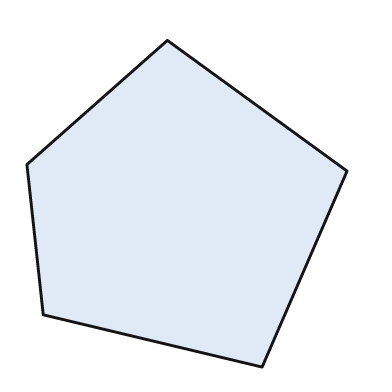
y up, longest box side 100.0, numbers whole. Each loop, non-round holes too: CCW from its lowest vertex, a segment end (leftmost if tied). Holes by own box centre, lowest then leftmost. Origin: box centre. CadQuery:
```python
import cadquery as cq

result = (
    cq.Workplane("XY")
    .moveTo(23.0, -50.0)
    .lineTo(49.0, 10.0)
    .lineTo(-6.0, 50.0)
    .lineTo(-49.0, 12.0)
    .lineTo(-44.0, -34.0)
    .close()
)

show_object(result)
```